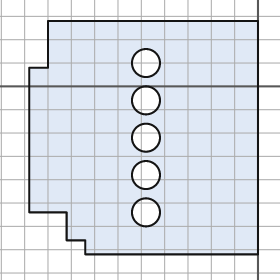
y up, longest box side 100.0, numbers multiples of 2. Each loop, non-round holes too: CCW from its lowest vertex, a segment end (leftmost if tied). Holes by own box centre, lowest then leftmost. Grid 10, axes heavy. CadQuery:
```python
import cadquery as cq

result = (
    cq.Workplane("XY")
    .moveTo(-74.0, -72.0)
    .lineTo(0.0, -72.0)
    .lineTo(0.0, 28.0)
    .lineTo(-90.0, 28.0)
    .lineTo(-90.0, 8.0)
    .lineTo(-98.0, 8.0)
    .lineTo(-98.0, -54.0)
    .lineTo(-82.0, -54.0)
    .lineTo(-82.0, -66.0)
    .lineTo(-74.0, -66.0)
    .close()
    .moveTo(-48.0, -54.0)
    .circle(6.0)
    .moveTo(-48.0, -38.0)
    .circle(6.0)
    .moveTo(-48.0, -22.0)
    .circle(6.0)
    .moveTo(-48.0, -6.0)
    .circle(6.0)
    .moveTo(-48.0, 10.0)
    .circle(6.0)
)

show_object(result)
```